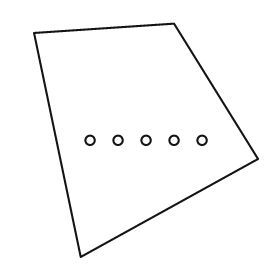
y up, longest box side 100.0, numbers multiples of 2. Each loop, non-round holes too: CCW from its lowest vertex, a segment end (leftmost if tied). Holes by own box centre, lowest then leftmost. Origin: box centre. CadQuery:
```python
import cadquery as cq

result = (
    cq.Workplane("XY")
    .moveTo(-28.0, -50.0)
    .lineTo(48.0, -8.0)
    .lineTo(12.0, 50.0)
    .lineTo(-48.0, 46.0)
    .close()
    .moveTo(-24.0, 0.0)
    .circle(2.0)
    .moveTo(-12.0, 0.0)
    .circle(2.0)
    .moveTo(0.0, 0.0)
    .circle(2.0)
    .moveTo(12.0, 0.0)
    .circle(2.0)
    .moveTo(24.0, 0.0)
    .circle(2.0)
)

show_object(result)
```